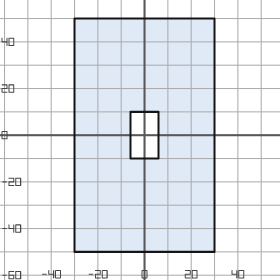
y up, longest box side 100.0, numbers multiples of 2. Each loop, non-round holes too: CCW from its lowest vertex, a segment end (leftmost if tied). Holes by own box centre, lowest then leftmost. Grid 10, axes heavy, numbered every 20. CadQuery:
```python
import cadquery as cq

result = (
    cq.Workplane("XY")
    .moveTo(-30.0, -50.0)
    .lineTo(30.0, -50.0)
    .lineTo(30.0, 50.0)
    .lineTo(-30.0, 50.0)
    .close()
    .moveTo(-6.0, -10.0)
    .lineTo(6.0, -10.0)
    .lineTo(6.0, 10.0)
    .lineTo(-6.0, 10.0)
    .close()
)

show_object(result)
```